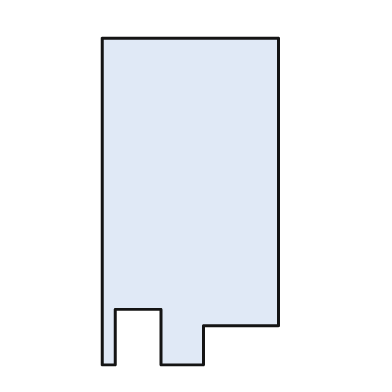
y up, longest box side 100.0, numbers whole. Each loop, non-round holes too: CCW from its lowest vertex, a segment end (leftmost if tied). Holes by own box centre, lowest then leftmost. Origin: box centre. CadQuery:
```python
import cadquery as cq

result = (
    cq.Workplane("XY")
    .moveTo(-27.0, -50.0)
    .lineTo(-23.0, -50.0)
    .lineTo(-23.0, -33.0)
    .lineTo(-9.0, -33.0)
    .lineTo(-9.0, -50.0)
    .lineTo(4.0, -50.0)
    .lineTo(4.0, -38.0)
    .lineTo(27.0, -38.0)
    .lineTo(27.0, 50.0)
    .lineTo(-27.0, 50.0)
    .close()
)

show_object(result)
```